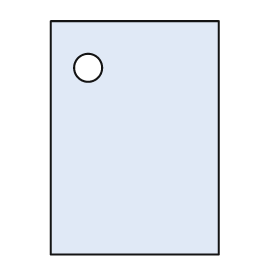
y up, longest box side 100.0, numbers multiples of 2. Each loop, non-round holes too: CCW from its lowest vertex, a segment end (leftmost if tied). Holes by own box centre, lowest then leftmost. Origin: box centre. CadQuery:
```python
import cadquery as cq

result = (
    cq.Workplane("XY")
    .moveTo(-36.0, -50.0)
    .lineTo(36.0, -50.0)
    .lineTo(36.0, 50.0)
    .lineTo(-36.0, 50.0)
    .close()
    .moveTo(-20.0, 30.0)
    .circle(6.0)
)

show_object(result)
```